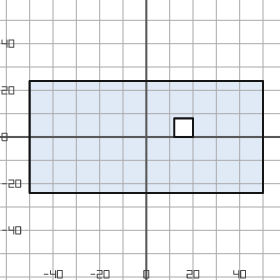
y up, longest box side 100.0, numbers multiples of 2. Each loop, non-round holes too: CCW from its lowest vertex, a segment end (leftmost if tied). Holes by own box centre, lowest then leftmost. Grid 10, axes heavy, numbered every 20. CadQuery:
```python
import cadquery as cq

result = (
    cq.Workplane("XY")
    .moveTo(-50.0, -24.0)
    .lineTo(50.0, -24.0)
    .lineTo(50.0, 24.0)
    .lineTo(-50.0, 24.0)
    .close()
    .moveTo(12.0, 0.0)
    .lineTo(20.0, 0.0)
    .lineTo(20.0, 8.0)
    .lineTo(12.0, 8.0)
    .close()
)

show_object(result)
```